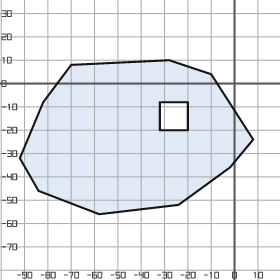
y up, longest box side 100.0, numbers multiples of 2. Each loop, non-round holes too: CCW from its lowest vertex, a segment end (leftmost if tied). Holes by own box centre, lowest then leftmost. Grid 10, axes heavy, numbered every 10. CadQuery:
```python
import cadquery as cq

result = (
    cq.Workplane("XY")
    .moveTo(-58.0, -56.0)
    .lineTo(-24.0, -52.0)
    .lineTo(-2.0, -36.0)
    .lineTo(8.0, -24.0)
    .lineTo(-10.0, 4.0)
    .lineTo(-28.0, 10.0)
    .lineTo(-70.0, 8.0)
    .lineTo(-82.0, -8.0)
    .lineTo(-92.0, -32.0)
    .lineTo(-84.0, -46.0)
    .close()
    .moveTo(-32.0, -20.0)
    .lineTo(-20.0, -20.0)
    .lineTo(-20.0, -8.0)
    .lineTo(-32.0, -8.0)
    .close()
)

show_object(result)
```